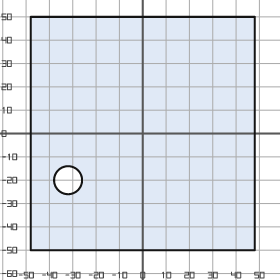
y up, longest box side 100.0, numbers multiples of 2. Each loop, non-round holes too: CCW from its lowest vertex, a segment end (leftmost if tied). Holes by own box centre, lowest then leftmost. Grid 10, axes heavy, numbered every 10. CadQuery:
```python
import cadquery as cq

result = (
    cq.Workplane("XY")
    .moveTo(-48.0, -50.0)
    .lineTo(48.0, -50.0)
    .lineTo(48.0, 50.0)
    .lineTo(-48.0, 50.0)
    .close()
    .moveTo(-32.0, -20.0)
    .circle(6.0)
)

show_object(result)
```